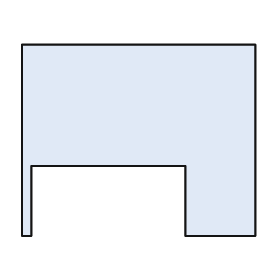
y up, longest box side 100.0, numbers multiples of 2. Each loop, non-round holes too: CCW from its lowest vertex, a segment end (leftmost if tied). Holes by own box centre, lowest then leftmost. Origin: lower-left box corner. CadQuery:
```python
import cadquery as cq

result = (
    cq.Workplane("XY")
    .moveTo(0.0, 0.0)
    .lineTo(4.0, 0.0)
    .lineTo(4.0, 30.0)
    .lineTo(70.0, 30.0)
    .lineTo(70.0, 0.0)
    .lineTo(100.0, 0.0)
    .lineTo(100.0, 82.0)
    .lineTo(0.0, 82.0)
    .close()
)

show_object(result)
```